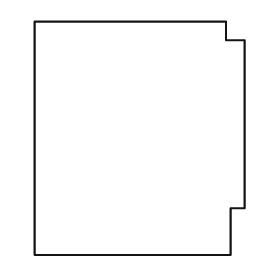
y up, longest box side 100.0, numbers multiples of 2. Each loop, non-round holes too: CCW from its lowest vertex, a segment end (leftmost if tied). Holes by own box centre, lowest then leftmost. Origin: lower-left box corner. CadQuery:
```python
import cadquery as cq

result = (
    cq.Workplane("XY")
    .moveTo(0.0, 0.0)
    .lineTo(84.0, 0.0)
    .lineTo(84.0, 20.0)
    .lineTo(90.0, 20.0)
    .lineTo(90.0, 92.0)
    .lineTo(82.0, 92.0)
    .lineTo(82.0, 100.0)
    .lineTo(0.0, 100.0)
    .close()
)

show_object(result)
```